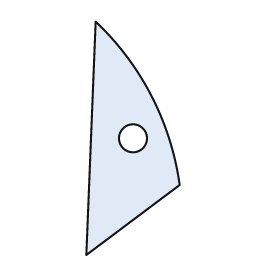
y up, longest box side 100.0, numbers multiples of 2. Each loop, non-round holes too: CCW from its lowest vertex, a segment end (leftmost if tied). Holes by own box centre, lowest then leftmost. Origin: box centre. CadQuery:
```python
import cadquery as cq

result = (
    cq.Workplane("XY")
    .moveTo(-20.0, -50.0)
    .lineTo(20.0, -20.0)
    .threePointArc((8.0, 18.0), (-16.0, 50.0))
    .close()
    .moveTo(0.0, 0.0)
    .circle(6.0)
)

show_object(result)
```